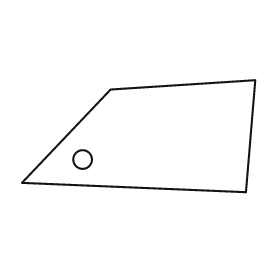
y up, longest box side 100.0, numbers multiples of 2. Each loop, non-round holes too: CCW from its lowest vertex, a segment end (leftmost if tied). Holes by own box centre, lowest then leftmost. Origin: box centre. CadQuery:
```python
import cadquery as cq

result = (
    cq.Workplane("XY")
    .moveTo(46.0, -24.0)
    .lineTo(50.0, 24.0)
    .lineTo(-12.0, 20.0)
    .lineTo(-50.0, -20.0)
    .close()
    .moveTo(-24.0, -10.0)
    .circle(4.0)
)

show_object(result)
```